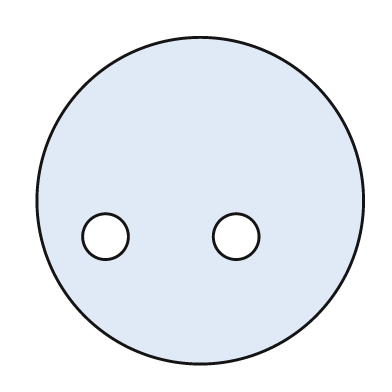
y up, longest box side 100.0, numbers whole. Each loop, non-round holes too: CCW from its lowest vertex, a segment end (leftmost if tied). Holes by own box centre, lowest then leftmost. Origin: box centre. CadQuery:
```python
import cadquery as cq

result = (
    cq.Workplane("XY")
    .moveTo(0.0, 0.0)
    .circle(50.0)
    .moveTo(-29.0, -11.0)
    .circle(7.0)
    .moveTo(11.0, -11.0)
    .circle(7.0)
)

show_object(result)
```